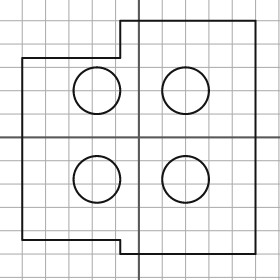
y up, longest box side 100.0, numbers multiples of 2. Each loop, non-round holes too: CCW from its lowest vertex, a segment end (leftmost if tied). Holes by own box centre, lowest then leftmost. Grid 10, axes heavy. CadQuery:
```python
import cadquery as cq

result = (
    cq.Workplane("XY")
    .moveTo(-8.0, -50.0)
    .lineTo(50.0, -50.0)
    .lineTo(50.0, 50.0)
    .lineTo(-8.0, 50.0)
    .lineTo(-8.0, 34.0)
    .lineTo(-50.0, 34.0)
    .lineTo(-50.0, -44.0)
    .lineTo(-8.0, -44.0)
    .close()
    .moveTo(-18.0, -18.0)
    .circle(10.0)
    .moveTo(20.0, -18.0)
    .circle(10.0)
    .moveTo(-18.0, 20.0)
    .circle(10.0)
    .moveTo(20.0, 20.0)
    .circle(10.0)
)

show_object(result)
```